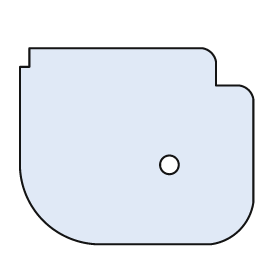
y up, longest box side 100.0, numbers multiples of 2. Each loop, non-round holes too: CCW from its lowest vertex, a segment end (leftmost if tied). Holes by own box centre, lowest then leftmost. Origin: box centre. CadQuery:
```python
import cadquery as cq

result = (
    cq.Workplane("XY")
    .moveTo(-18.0, -42.0)
    .lineTo(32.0, -42.0)
    .threePointArc((44.0, -36.0), (50.0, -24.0))
    .lineTo(50.0, 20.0)
    .threePointArc((48.0, 24.0), (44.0, 26.0))
    .lineTo(34.0, 26.0)
    .lineTo(34.0, 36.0)
    .threePointArc((32.0, 40.0), (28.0, 42.0))
    .lineTo(-46.0, 42.0)
    .lineTo(-46.0, 34.0)
    .lineTo(-50.0, 34.0)
    .lineTo(-50.0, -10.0)
    .threePointArc((-40.0, -32.0), (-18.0, -42.0))
    .close()
    .moveTo(14.0, -8.0)
    .circle(4.0)
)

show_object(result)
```